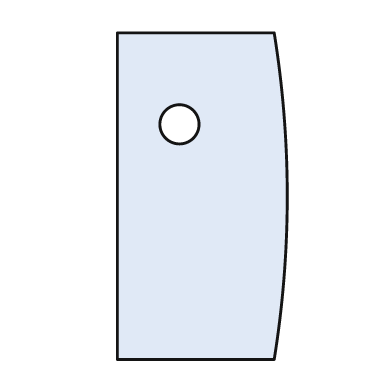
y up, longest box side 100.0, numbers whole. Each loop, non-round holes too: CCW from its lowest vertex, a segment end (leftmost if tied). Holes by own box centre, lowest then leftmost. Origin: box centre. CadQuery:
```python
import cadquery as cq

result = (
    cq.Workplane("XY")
    .moveTo(-26.0, -50.0)
    .lineTo(22.0, -50.0)
    .threePointArc((26.0, 0.0), (22.0, 50.0))
    .lineTo(-26.0, 50.0)
    .close()
    .moveTo(-7.0, 22.0)
    .circle(6.0)
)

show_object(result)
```